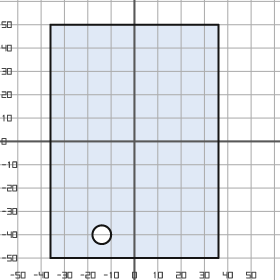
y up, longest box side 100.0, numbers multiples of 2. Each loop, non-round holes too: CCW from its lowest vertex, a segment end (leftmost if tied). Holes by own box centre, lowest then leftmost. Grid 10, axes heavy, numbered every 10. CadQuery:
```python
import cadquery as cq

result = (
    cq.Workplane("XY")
    .moveTo(-36.0, -50.0)
    .lineTo(36.0, -50.0)
    .lineTo(36.0, 50.0)
    .lineTo(-36.0, 50.0)
    .close()
    .moveTo(-14.0, -40.0)
    .circle(4.0)
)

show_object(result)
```